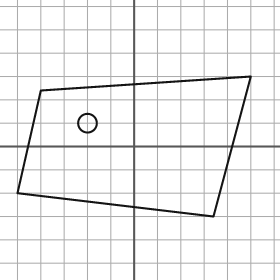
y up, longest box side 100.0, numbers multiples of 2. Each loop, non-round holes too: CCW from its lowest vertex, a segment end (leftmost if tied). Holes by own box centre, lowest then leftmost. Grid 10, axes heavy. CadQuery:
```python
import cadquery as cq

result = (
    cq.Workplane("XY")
    .moveTo(34.0, -30.0)
    .lineTo(50.0, 30.0)
    .lineTo(-40.0, 24.0)
    .lineTo(-50.0, -20.0)
    .close()
    .moveTo(-20.0, 10.0)
    .circle(4.0)
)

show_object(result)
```